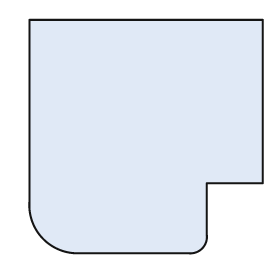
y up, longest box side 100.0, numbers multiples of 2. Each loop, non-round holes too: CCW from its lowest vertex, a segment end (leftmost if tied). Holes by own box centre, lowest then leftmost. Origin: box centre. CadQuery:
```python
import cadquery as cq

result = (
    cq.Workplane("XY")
    .moveTo(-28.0, -50.0)
    .lineTo(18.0, -50.0)
    .threePointArc((24.0, -48.0), (26.0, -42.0))
    .lineTo(26.0, -20.0)
    .lineTo(50.0, -20.0)
    .lineTo(50.0, 50.0)
    .lineTo(-50.0, 50.0)
    .lineTo(-50.0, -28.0)
    .threePointArc((-44.0, -44.0), (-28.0, -50.0))
    .close()
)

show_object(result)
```